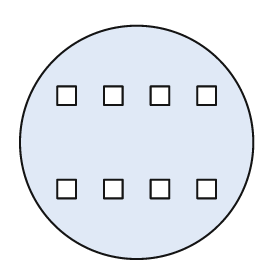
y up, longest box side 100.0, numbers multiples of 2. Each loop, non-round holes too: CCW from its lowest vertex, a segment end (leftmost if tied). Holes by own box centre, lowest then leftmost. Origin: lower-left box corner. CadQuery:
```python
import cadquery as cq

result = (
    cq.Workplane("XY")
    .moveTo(50.0, 50.0)
    .circle(50.0)
    .moveTo(16.0, 26.0)
    .lineTo(24.0, 26.0)
    .lineTo(24.0, 34.0)
    .lineTo(16.0, 34.0)
    .close()
    .moveTo(36.0, 26.0)
    .lineTo(44.0, 26.0)
    .lineTo(44.0, 34.0)
    .lineTo(36.0, 34.0)
    .close()
    .moveTo(56.0, 26.0)
    .lineTo(64.0, 26.0)
    .lineTo(64.0, 34.0)
    .lineTo(56.0, 34.0)
    .close()
    .moveTo(76.0, 26.0)
    .lineTo(84.0, 26.0)
    .lineTo(84.0, 34.0)
    .lineTo(76.0, 34.0)
    .close()
    .moveTo(16.0, 66.0)
    .lineTo(24.0, 66.0)
    .lineTo(24.0, 74.0)
    .lineTo(16.0, 74.0)
    .close()
    .moveTo(36.0, 66.0)
    .lineTo(44.0, 66.0)
    .lineTo(44.0, 74.0)
    .lineTo(36.0, 74.0)
    .close()
    .moveTo(56.0, 66.0)
    .lineTo(64.0, 66.0)
    .lineTo(64.0, 74.0)
    .lineTo(56.0, 74.0)
    .close()
    .moveTo(76.0, 66.0)
    .lineTo(84.0, 66.0)
    .lineTo(84.0, 74.0)
    .lineTo(76.0, 74.0)
    .close()
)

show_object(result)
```